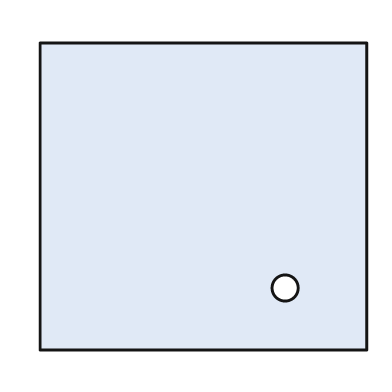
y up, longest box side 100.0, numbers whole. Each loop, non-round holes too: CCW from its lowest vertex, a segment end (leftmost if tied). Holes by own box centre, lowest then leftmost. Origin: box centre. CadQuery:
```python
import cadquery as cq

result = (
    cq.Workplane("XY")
    .moveTo(-50.0, -47.0)
    .lineTo(50.0, -47.0)
    .lineTo(50.0, 47.0)
    .lineTo(-50.0, 47.0)
    .close()
    .moveTo(25.0, -28.0)
    .circle(4.0)
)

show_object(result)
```